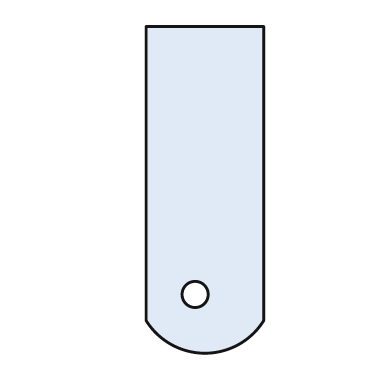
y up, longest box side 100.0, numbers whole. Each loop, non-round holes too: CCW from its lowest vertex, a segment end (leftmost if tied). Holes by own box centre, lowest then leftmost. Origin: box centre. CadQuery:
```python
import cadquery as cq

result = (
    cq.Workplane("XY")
    .moveTo(-18.0, -40.0)
    .threePointArc((0.0, -50.0), (18.0, -40.0))
    .lineTo(18.0, 50.0)
    .lineTo(-18.0, 50.0)
    .close()
    .moveTo(-3.0, -32.0)
    .circle(4.0)
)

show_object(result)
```